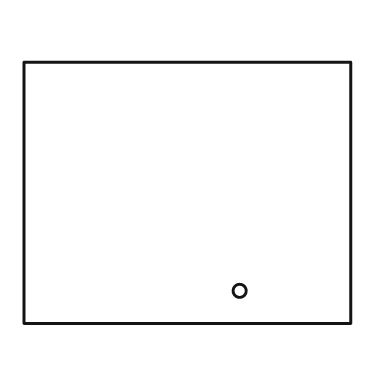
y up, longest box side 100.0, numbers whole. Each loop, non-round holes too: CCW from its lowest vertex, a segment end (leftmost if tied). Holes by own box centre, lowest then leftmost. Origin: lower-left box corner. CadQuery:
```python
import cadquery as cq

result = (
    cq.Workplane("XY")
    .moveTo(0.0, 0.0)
    .lineTo(100.0, 0.0)
    .lineTo(100.0, 80.0)
    .lineTo(0.0, 80.0)
    .close()
    .moveTo(66.0, 10.0)
    .circle(2.0)
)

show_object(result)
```